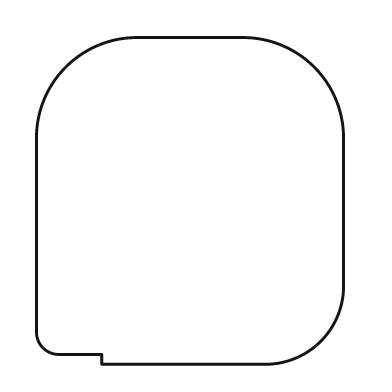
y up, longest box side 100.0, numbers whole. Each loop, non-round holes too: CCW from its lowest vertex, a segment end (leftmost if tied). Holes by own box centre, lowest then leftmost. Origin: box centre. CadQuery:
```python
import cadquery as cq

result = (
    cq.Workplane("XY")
    .moveTo(-27.0, -50.0)
    .lineTo(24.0, -50.0)
    .threePointArc((40.0, -43.0), (47.0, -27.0))
    .lineTo(47.0, 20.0)
    .threePointArc((38.0, 41.0), (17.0, 50.0))
    .lineTo(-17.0, 50.0)
    .threePointArc((-38.0, 41.0), (-47.0, 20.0))
    .lineTo(-47.0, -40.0)
    .threePointArc((-45.0, -45.0), (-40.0, -47.0))
    .lineTo(-27.0, -47.0)
    .close()
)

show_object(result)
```